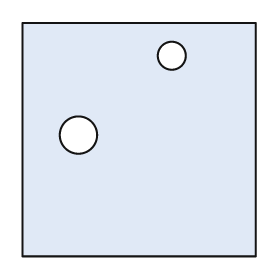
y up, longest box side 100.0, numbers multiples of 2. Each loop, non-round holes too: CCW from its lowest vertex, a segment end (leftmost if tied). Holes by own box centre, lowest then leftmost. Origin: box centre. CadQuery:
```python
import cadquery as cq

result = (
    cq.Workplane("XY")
    .moveTo(-50.0, -50.0)
    .lineTo(50.0, -50.0)
    .lineTo(50.0, 50.0)
    .lineTo(-50.0, 50.0)
    .close()
    .moveTo(-26.0, 2.0)
    .circle(8.0)
    .moveTo(14.0, 36.0)
    .circle(6.0)
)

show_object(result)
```